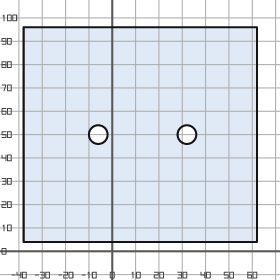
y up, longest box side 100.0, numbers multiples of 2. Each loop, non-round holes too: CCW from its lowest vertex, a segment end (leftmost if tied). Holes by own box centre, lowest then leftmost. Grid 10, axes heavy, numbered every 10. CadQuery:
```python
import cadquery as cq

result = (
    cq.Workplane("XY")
    .moveTo(-38.0, 4.0)
    .lineTo(62.0, 4.0)
    .lineTo(62.0, 96.0)
    .lineTo(-38.0, 96.0)
    .close()
    .moveTo(-6.0, 50.0)
    .circle(4.0)
    .moveTo(32.0, 50.0)
    .circle(4.0)
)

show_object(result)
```